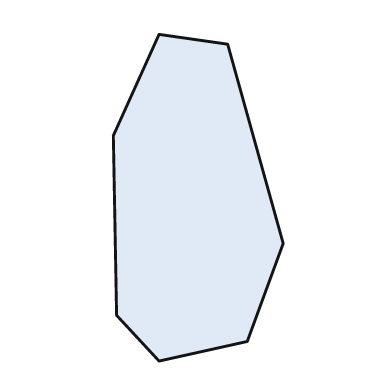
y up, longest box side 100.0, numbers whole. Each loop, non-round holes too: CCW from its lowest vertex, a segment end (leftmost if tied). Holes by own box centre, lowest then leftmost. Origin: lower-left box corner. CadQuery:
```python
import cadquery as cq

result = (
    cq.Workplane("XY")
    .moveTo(14.0, 0.0)
    .lineTo(41.0, 6.0)
    .lineTo(52.0, 36.0)
    .lineTo(35.0, 97.0)
    .lineTo(14.0, 100.0)
    .lineTo(0.0, 69.0)
    .lineTo(1.0, 14.0)
    .close()
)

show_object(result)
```